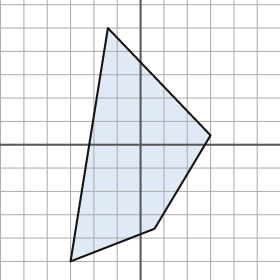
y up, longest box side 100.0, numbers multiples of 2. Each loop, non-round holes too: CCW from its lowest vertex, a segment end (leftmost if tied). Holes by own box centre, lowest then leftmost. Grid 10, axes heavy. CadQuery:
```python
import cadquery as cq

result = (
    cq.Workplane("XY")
    .moveTo(-30.0, -50.0)
    .lineTo(6.0, -36.0)
    .lineTo(30.0, 4.0)
    .lineTo(-14.0, 50.0)
    .close()
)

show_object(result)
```